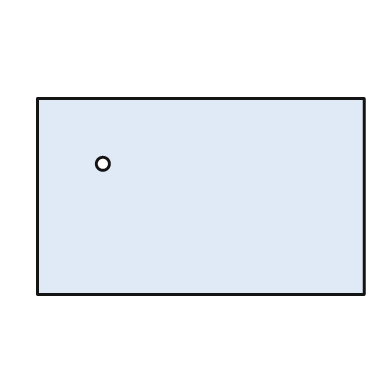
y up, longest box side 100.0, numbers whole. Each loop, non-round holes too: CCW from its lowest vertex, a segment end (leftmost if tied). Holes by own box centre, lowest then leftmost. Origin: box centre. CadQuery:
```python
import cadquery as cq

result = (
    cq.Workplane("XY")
    .moveTo(-50.0, -30.0)
    .lineTo(50.0, -30.0)
    .lineTo(50.0, 30.0)
    .lineTo(-50.0, 30.0)
    .close()
    .moveTo(-30.0, 10.0)
    .circle(2.0)
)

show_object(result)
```